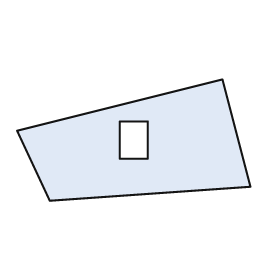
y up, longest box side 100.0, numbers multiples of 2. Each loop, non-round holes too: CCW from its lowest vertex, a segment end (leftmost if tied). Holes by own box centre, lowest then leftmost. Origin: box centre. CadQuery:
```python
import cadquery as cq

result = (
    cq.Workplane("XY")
    .moveTo(-36.0, -26.0)
    .lineTo(50.0, -20.0)
    .lineTo(38.0, 26.0)
    .lineTo(-50.0, 4.0)
    .close()
    .moveTo(-6.0, -8.0)
    .lineTo(6.0, -8.0)
    .lineTo(6.0, 8.0)
    .lineTo(-6.0, 8.0)
    .close()
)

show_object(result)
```